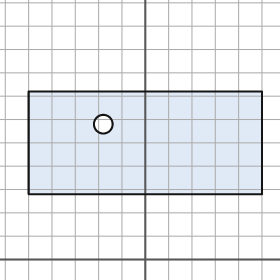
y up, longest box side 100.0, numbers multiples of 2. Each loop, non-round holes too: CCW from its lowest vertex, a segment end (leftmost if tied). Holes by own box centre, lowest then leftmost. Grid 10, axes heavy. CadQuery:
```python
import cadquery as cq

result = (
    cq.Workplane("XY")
    .moveTo(-50.0, 28.0)
    .lineTo(50.0, 28.0)
    .lineTo(50.0, 72.0)
    .lineTo(-50.0, 72.0)
    .close()
    .moveTo(-18.0, 58.0)
    .circle(4.0)
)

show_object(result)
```